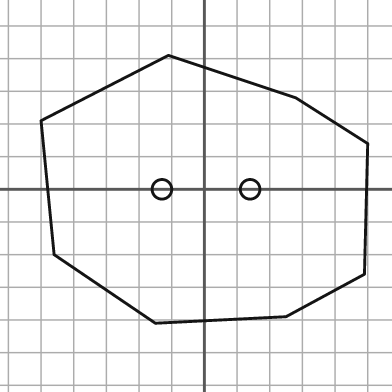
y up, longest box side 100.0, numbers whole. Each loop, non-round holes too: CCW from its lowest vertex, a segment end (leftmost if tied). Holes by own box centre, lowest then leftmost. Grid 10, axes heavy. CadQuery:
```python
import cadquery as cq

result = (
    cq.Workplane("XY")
    .moveTo(-15.0, -41.0)
    .lineTo(25.0, -39.0)
    .lineTo(49.0, -26.0)
    .lineTo(50.0, 14.0)
    .lineTo(28.0, 28.0)
    .lineTo(-11.0, 41.0)
    .lineTo(-50.0, 21.0)
    .lineTo(-46.0, -20.0)
    .close()
    .moveTo(-13.0, 0.0)
    .circle(3.0)
    .moveTo(14.0, 0.0)
    .circle(3.0)
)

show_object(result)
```